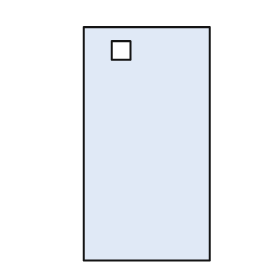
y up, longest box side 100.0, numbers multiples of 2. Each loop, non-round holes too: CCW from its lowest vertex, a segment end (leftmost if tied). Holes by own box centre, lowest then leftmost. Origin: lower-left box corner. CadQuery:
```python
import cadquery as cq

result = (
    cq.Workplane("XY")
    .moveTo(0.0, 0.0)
    .lineTo(54.0, 0.0)
    .lineTo(54.0, 100.0)
    .lineTo(0.0, 100.0)
    .close()
    .moveTo(12.0, 86.0)
    .lineTo(20.0, 86.0)
    .lineTo(20.0, 94.0)
    .lineTo(12.0, 94.0)
    .close()
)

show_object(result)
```